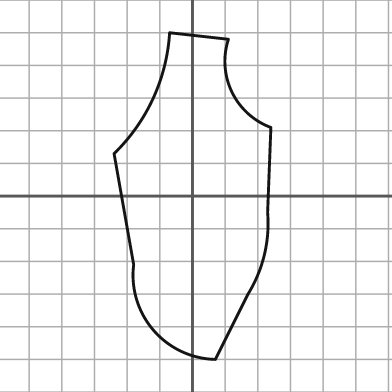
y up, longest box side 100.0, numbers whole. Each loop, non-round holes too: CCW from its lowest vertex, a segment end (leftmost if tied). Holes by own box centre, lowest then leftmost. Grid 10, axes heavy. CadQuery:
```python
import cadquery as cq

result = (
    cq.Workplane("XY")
    .moveTo(7.0, -50.0)
    .lineTo(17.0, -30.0)
    .threePointArc((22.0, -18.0), (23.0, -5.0))
    .lineTo(24.0, 21.0)
    .threePointArc((12.0, 32.0), (11.0, 48.0))
    .lineTo(-7.0, 50.0)
    .threePointArc((-12.0, 30.0), (-24.0, 13.0))
    .lineTo(-18.0, -21.0)
    .threePointArc((-12.0, -41.0), (7.0, -50.0))
    .close()
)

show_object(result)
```